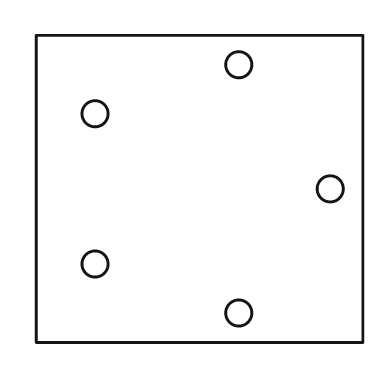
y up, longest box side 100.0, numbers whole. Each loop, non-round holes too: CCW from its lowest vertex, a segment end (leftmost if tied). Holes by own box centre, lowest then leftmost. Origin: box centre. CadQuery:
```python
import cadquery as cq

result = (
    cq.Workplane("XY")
    .moveTo(-50.0, -47.0)
    .lineTo(50.0, -47.0)
    .lineTo(50.0, 47.0)
    .lineTo(-50.0, 47.0)
    .close()
    .moveTo(12.0, -38.0)
    .circle(4.0)
    .moveTo(-32.0, -23.0)
    .circle(4.0)
    .moveTo(40.0, 0.0)
    .circle(4.0)
    .moveTo(-32.0, 23.0)
    .circle(4.0)
    .moveTo(12.0, 38.0)
    .circle(4.0)
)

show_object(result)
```